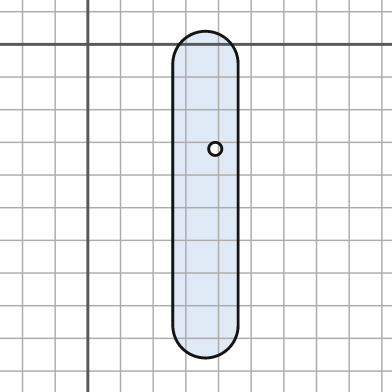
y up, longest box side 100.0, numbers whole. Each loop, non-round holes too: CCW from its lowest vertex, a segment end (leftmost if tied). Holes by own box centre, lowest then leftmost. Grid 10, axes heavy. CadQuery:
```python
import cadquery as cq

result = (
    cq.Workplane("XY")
    .moveTo(26.0, -86.0)
    .threePointArc((36.0, -96.0), (46.0, -86.0))
    .lineTo(46.0, -6.0)
    .threePointArc((36.0, 4.0), (26.0, -6.0))
    .close()
    .moveTo(39.0, -32.0)
    .circle(2.0)
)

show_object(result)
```